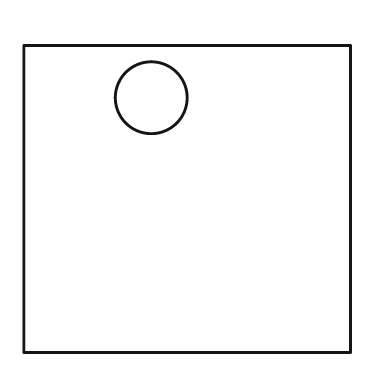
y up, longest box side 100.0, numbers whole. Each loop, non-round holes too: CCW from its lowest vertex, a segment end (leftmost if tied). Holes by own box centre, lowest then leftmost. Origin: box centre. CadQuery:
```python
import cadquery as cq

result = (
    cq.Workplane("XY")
    .moveTo(-50.0, -47.0)
    .lineTo(50.0, -47.0)
    .lineTo(50.0, 47.0)
    .lineTo(-50.0, 47.0)
    .close()
    .moveTo(-11.0, 31.0)
    .circle(11.0)
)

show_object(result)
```